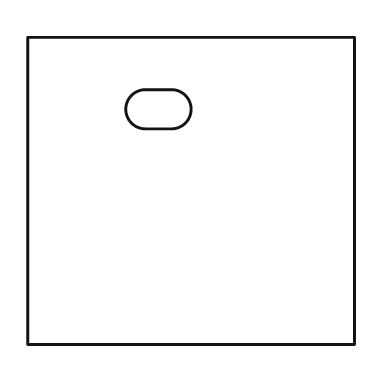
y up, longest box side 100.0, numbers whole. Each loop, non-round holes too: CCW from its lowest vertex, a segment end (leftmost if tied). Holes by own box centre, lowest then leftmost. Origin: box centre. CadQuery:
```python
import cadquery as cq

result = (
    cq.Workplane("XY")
    .moveTo(-50.0, -47.0)
    .lineTo(50.0, -47.0)
    .lineTo(50.0, 47.0)
    .lineTo(-50.0, 47.0)
    .close()
    .moveTo(-14.0, 19.0)
    .lineTo(-6.0, 19.0)
    .threePointArc((0.0, 25.0), (-6.0, 31.0))
    .lineTo(-14.0, 31.0)
    .threePointArc((-20.0, 25.0), (-14.0, 19.0))
    .close()
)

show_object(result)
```